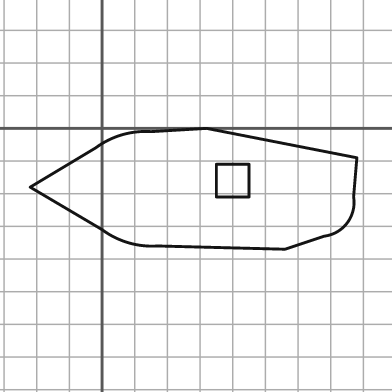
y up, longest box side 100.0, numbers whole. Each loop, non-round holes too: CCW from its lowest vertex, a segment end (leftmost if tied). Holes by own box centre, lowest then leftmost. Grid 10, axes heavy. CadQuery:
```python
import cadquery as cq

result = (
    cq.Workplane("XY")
    .moveTo(56.0, -37.0)
    .lineTo(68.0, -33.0)
    .threePointArc((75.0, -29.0), (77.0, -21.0))
    .lineTo(78.0, -9.0)
    .lineTo(32.0, 0.0)
    .lineTo(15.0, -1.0)
    .threePointArc((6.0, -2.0), (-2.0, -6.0))
    .lineTo(-22.0, -18.0)
    .lineTo(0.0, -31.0)
    .threePointArc((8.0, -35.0), (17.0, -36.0))
    .close()
    .moveTo(35.0, -21.0)
    .lineTo(45.0, -21.0)
    .lineTo(45.0, -11.0)
    .lineTo(35.0, -11.0)
    .close()
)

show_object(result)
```